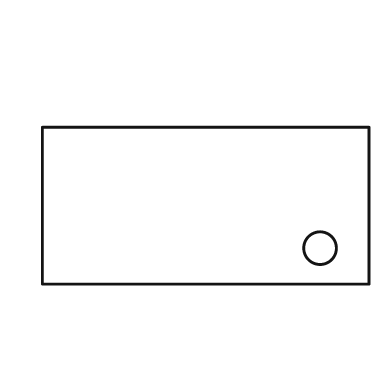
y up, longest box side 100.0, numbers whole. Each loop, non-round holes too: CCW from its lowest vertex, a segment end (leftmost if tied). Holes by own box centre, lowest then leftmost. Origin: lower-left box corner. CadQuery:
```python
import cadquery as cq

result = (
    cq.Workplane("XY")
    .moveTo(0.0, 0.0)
    .lineTo(100.0, 0.0)
    .lineTo(100.0, 48.0)
    .lineTo(0.0, 48.0)
    .close()
    .moveTo(85.0, 11.0)
    .circle(5.0)
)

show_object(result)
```